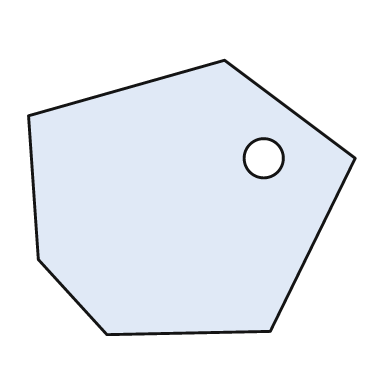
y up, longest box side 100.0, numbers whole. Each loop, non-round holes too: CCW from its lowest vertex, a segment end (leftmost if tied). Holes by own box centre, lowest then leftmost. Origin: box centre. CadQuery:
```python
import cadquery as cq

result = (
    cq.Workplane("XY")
    .moveTo(-26.0, -42.0)
    .lineTo(24.0, -41.0)
    .lineTo(50.0, 12.0)
    .lineTo(10.0, 42.0)
    .lineTo(-50.0, 25.0)
    .lineTo(-47.0, -19.0)
    .close()
    .moveTo(22.0, 12.0)
    .circle(6.0)
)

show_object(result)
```